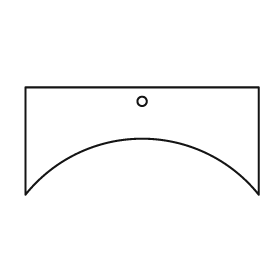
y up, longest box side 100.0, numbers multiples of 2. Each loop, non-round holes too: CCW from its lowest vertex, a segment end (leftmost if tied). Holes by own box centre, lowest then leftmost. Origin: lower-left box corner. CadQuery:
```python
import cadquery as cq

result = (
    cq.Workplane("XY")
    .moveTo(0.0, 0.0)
    .threePointArc((50.0, 24.0), (100.0, 0.0))
    .lineTo(100.0, 46.0)
    .lineTo(0.0, 46.0)
    .close()
    .moveTo(50.0, 40.0)
    .circle(2.0)
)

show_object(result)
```